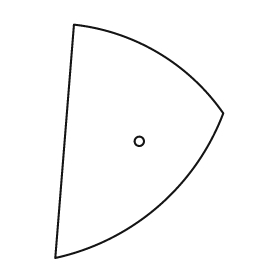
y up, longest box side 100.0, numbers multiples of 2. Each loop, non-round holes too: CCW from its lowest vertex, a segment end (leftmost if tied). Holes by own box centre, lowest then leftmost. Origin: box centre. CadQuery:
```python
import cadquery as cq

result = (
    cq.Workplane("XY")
    .moveTo(-36.0, -50.0)
    .threePointArc((8.0, -28.0), (36.0, 12.0))
    .threePointArc((8.0, 38.0), (-28.0, 50.0))
    .close()
    .moveTo(0.0, 0.0)
    .circle(2.0)
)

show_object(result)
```